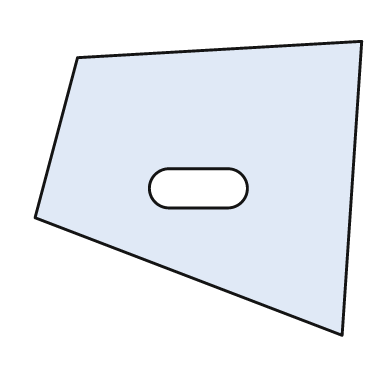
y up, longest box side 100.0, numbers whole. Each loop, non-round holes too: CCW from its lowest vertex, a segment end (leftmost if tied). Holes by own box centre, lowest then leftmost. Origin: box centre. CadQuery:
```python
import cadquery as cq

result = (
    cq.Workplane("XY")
    .moveTo(44.0, -45.0)
    .lineTo(50.0, 45.0)
    .lineTo(-37.0, 40.0)
    .lineTo(-50.0, -9.0)
    .close()
    .moveTo(-9.0, -6.0)
    .lineTo(9.0, -6.0)
    .threePointArc((15.0, 0.0), (9.0, 6.0))
    .lineTo(-9.0, 6.0)
    .threePointArc((-15.0, 0.0), (-9.0, -6.0))
    .close()
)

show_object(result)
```